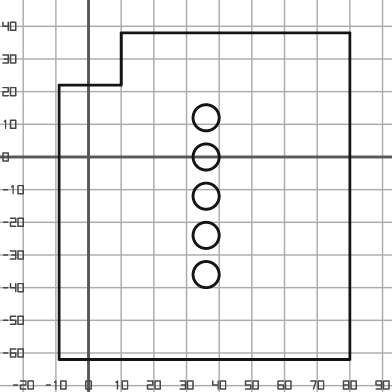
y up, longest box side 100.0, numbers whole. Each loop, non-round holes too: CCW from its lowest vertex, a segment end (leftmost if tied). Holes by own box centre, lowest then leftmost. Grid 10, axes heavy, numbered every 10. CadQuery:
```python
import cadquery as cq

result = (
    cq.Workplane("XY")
    .moveTo(-9.0, -62.0)
    .lineTo(80.0, -62.0)
    .lineTo(80.0, 38.0)
    .lineTo(10.0, 38.0)
    .lineTo(10.0, 22.0)
    .lineTo(-9.0, 22.0)
    .close()
    .moveTo(36.0, -36.0)
    .circle(4.0)
    .moveTo(36.0, -24.0)
    .circle(4.0)
    .moveTo(36.0, -12.0)
    .circle(4.0)
    .moveTo(36.0, 0.0)
    .circle(4.0)
    .moveTo(36.0, 12.0)
    .circle(4.0)
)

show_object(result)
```